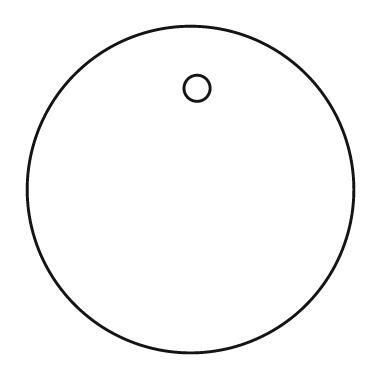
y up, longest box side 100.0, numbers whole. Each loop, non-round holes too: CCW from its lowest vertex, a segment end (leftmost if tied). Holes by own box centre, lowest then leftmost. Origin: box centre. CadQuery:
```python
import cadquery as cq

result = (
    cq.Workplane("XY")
    .moveTo(0.0, 0.0)
    .circle(50.0)
    .moveTo(2.0, 31.0)
    .circle(4.0)
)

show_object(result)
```